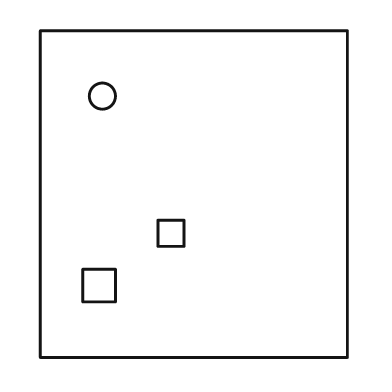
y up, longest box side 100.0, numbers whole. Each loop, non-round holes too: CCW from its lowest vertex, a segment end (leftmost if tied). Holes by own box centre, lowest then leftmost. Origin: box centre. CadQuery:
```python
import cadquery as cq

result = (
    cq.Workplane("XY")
    .moveTo(-47.0, -50.0)
    .lineTo(47.0, -50.0)
    .lineTo(47.0, 50.0)
    .lineTo(-47.0, 50.0)
    .close()
    .moveTo(-34.0, -33.0)
    .lineTo(-24.0, -33.0)
    .lineTo(-24.0, -23.0)
    .lineTo(-34.0, -23.0)
    .close()
    .moveTo(-11.0, -16.0)
    .lineTo(-3.0, -16.0)
    .lineTo(-3.0, -8.0)
    .lineTo(-11.0, -8.0)
    .close()
    .moveTo(-28.0, 30.0)
    .circle(4.0)
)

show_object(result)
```